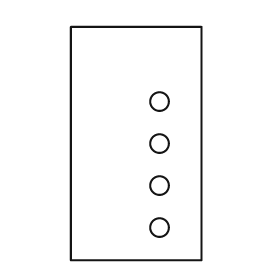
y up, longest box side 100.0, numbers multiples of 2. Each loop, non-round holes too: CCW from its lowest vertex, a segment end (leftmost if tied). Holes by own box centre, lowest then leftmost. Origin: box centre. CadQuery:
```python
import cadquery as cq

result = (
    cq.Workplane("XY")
    .moveTo(-28.0, -50.0)
    .lineTo(28.0, -50.0)
    .lineTo(28.0, 50.0)
    .lineTo(-28.0, 50.0)
    .close()
    .moveTo(10.0, -36.0)
    .circle(4.0)
    .moveTo(10.0, -18.0)
    .circle(4.0)
    .moveTo(10.0, 0.0)
    .circle(4.0)
    .moveTo(10.0, 18.0)
    .circle(4.0)
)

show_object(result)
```